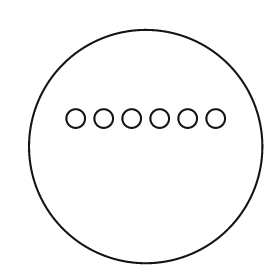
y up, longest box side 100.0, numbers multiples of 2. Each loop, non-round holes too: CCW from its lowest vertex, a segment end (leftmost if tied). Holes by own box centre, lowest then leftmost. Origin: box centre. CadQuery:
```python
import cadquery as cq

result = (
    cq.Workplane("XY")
    .moveTo(0.0, 0.0)
    .circle(50.0)
    .moveTo(-30.0, 12.0)
    .circle(4.0)
    .moveTo(-18.0, 12.0)
    .circle(4.0)
    .moveTo(-6.0, 12.0)
    .circle(4.0)
    .moveTo(6.0, 12.0)
    .circle(4.0)
    .moveTo(18.0, 12.0)
    .circle(4.0)
    .moveTo(30.0, 12.0)
    .circle(4.0)
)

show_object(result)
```